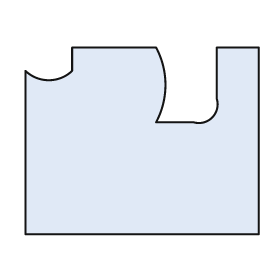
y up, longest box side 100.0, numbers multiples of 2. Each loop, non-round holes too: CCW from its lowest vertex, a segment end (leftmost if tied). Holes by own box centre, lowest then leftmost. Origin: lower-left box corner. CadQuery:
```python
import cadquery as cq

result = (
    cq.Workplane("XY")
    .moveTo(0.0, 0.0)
    .lineTo(100.0, 0.0)
    .lineTo(100.0, 80.0)
    .lineTo(82.0, 80.0)
    .lineTo(82.0, 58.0)
    .threePointArc((80.0, 50.0), (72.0, 48.0))
    .lineTo(56.0, 48.0)
    .threePointArc((60.0, 64.0), (56.0, 80.0))
    .lineTo(20.0, 80.0)
    .lineTo(20.0, 70.0)
    .threePointArc((10.0, 66.0), (0.0, 70.0))
    .close()
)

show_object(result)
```